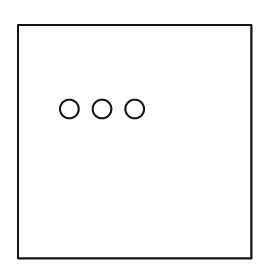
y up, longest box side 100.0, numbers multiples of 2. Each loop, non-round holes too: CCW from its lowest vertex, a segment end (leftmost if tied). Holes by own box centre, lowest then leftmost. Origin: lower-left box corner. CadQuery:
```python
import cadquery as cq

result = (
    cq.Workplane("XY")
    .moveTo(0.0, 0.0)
    .lineTo(100.0, 0.0)
    .lineTo(100.0, 100.0)
    .lineTo(0.0, 100.0)
    .close()
    .moveTo(22.0, 64.0)
    .circle(4.0)
    .moveTo(36.0, 64.0)
    .circle(4.0)
    .moveTo(50.0, 64.0)
    .circle(4.0)
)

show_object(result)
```